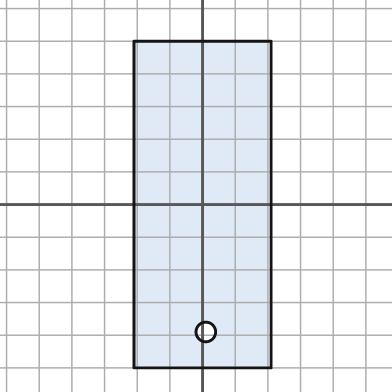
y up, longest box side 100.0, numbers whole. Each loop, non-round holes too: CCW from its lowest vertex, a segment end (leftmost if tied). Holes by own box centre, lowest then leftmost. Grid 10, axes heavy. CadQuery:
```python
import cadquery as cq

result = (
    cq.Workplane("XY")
    .moveTo(-21.0, -50.0)
    .lineTo(21.0, -50.0)
    .lineTo(21.0, 50.0)
    .lineTo(-21.0, 50.0)
    .close()
    .moveTo(1.0, -39.0)
    .circle(3.0)
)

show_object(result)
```